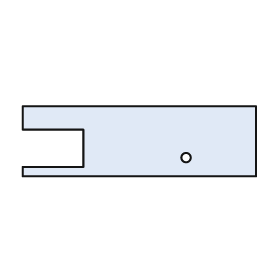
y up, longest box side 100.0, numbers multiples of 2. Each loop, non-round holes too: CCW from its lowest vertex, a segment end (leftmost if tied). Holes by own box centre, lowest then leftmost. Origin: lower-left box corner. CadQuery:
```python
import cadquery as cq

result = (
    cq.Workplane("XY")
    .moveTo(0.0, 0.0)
    .lineTo(100.0, 0.0)
    .lineTo(100.0, 30.0)
    .lineTo(0.0, 30.0)
    .lineTo(0.0, 20.0)
    .lineTo(26.0, 20.0)
    .lineTo(26.0, 4.0)
    .lineTo(0.0, 4.0)
    .close()
    .moveTo(70.0, 8.0)
    .circle(2.0)
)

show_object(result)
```